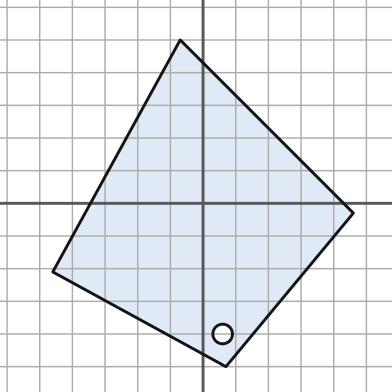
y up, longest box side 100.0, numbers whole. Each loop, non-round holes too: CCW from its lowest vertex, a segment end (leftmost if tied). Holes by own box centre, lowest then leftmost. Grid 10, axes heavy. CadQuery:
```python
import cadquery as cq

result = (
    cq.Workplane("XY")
    .moveTo(7.0, -50.0)
    .lineTo(46.0, -3.0)
    .lineTo(-7.0, 50.0)
    .lineTo(-46.0, -21.0)
    .close()
    .moveTo(6.0, -40.0)
    .circle(3.0)
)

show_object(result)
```